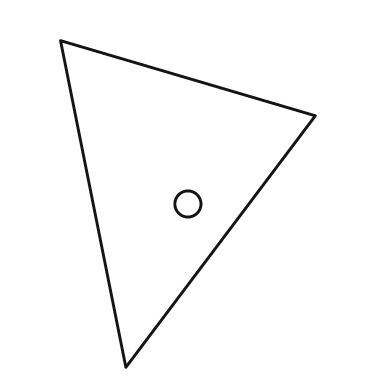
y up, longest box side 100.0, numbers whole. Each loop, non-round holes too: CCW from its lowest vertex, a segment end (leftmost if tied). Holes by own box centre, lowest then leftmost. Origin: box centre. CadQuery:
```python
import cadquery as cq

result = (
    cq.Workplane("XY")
    .moveTo(-19.0, -50.0)
    .lineTo(39.0, 27.0)
    .lineTo(-39.0, 50.0)
    .close()
    .moveTo(0.0, 0.0)
    .circle(4.0)
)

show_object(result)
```